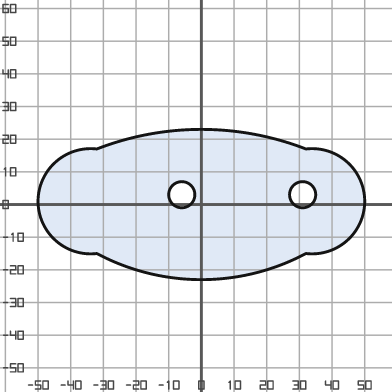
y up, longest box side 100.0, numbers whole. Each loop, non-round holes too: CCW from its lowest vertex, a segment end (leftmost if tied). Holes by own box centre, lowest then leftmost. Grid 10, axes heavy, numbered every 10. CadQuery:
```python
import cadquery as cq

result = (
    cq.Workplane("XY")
    .moveTo(-32.0, -15.0)
    .threePointArc((0.0, -23.0), (32.0, -15.0))
    .threePointArc((50.0, 1.0), (32.0, 17.0))
    .threePointArc((0.0, 23.0), (-32.0, 17.0))
    .threePointArc((-50.0, 1.0), (-32.0, -15.0))
    .close()
    .moveTo(-6.0, 3.0)
    .circle(4.0)
    .moveTo(31.0, 3.0)
    .circle(4.0)
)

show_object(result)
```